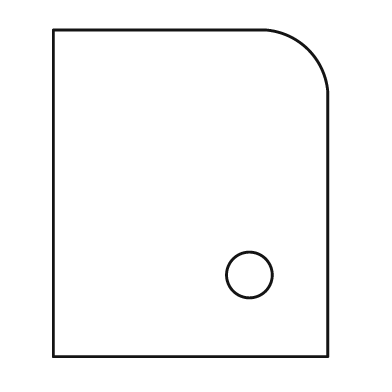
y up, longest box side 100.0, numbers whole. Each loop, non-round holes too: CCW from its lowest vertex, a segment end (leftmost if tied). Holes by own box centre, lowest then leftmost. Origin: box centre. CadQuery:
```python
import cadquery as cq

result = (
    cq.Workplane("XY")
    .moveTo(-42.0, -50.0)
    .lineTo(42.0, -50.0)
    .lineTo(42.0, 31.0)
    .threePointArc((36.0, 44.0), (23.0, 50.0))
    .lineTo(-42.0, 50.0)
    .close()
    .moveTo(18.0, -25.0)
    .circle(7.0)
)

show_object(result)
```